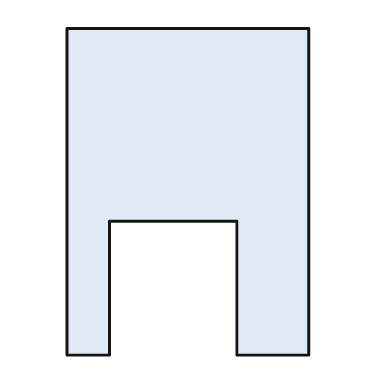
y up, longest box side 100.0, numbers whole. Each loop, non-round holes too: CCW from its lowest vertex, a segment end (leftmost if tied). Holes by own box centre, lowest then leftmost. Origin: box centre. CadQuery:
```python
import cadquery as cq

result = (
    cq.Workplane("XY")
    .moveTo(-37.0, -50.0)
    .lineTo(-24.0, -50.0)
    .lineTo(-24.0, -9.0)
    .lineTo(15.0, -9.0)
    .lineTo(15.0, -50.0)
    .lineTo(37.0, -50.0)
    .lineTo(37.0, 50.0)
    .lineTo(-37.0, 50.0)
    .close()
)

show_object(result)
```